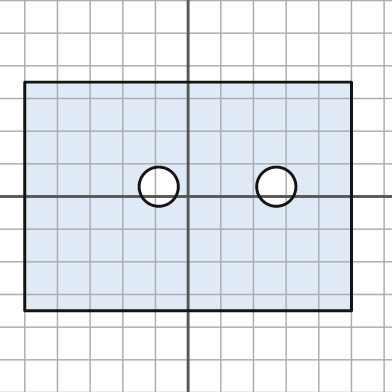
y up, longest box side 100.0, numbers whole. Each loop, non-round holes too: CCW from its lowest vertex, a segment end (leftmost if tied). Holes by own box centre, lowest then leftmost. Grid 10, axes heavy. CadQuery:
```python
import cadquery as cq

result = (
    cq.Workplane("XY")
    .moveTo(-50.0, -35.0)
    .lineTo(50.0, -35.0)
    .lineTo(50.0, 35.0)
    .lineTo(-50.0, 35.0)
    .close()
    .moveTo(-9.0, 3.0)
    .circle(6.0)
    .moveTo(27.0, 3.0)
    .circle(6.0)
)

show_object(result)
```